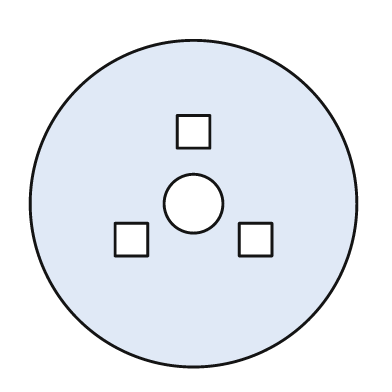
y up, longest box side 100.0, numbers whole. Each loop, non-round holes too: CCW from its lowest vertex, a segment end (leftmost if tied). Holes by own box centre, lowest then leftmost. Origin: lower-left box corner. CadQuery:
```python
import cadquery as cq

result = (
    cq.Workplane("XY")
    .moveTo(50.0, 50.0)
    .circle(50.0)
    .moveTo(26.0, 34.0)
    .lineTo(36.0, 34.0)
    .lineTo(36.0, 44.0)
    .lineTo(26.0, 44.0)
    .close()
    .moveTo(64.0, 34.0)
    .lineTo(74.0, 34.0)
    .lineTo(74.0, 44.0)
    .lineTo(64.0, 44.0)
    .close()
    .moveTo(50.0, 50.0)
    .circle(9.0)
    .moveTo(45.0, 67.0)
    .lineTo(55.0, 67.0)
    .lineTo(55.0, 77.0)
    .lineTo(45.0, 77.0)
    .close()
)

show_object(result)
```